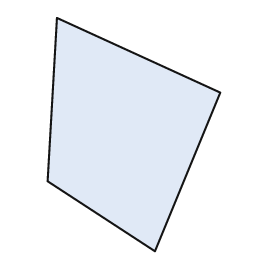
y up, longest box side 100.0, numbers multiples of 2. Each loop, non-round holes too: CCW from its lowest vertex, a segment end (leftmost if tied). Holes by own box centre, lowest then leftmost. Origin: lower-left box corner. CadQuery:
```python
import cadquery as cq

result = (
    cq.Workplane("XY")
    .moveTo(46.0, 0.0)
    .lineTo(74.0, 68.0)
    .lineTo(4.0, 100.0)
    .lineTo(0.0, 30.0)
    .close()
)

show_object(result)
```